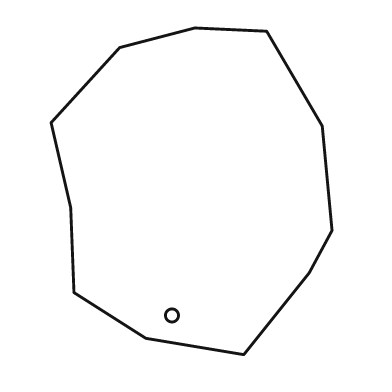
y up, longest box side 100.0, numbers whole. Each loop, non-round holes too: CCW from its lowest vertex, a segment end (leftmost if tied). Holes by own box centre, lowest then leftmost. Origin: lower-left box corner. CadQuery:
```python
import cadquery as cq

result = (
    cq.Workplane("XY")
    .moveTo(59.0, 0.0)
    .lineTo(79.0, 25.0)
    .lineTo(86.0, 38.0)
    .lineTo(83.0, 70.0)
    .lineTo(66.0, 99.0)
    .lineTo(44.0, 100.0)
    .lineTo(21.0, 94.0)
    .lineTo(0.0, 71.0)
    .lineTo(6.0, 45.0)
    .lineTo(7.0, 19.0)
    .lineTo(29.0, 5.0)
    .close()
    .moveTo(37.0, 12.0)
    .circle(2.0)
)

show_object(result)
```